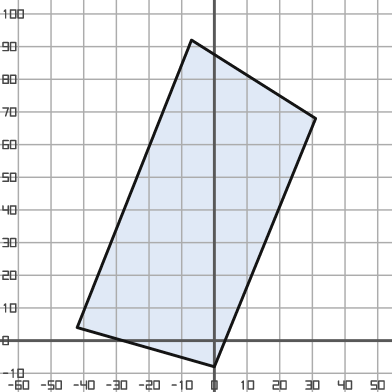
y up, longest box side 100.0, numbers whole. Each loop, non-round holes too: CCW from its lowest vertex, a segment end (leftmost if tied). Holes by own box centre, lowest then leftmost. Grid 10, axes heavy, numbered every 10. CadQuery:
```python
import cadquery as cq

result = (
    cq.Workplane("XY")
    .moveTo(0.0, -8.0)
    .lineTo(31.0, 68.0)
    .lineTo(-7.0, 92.0)
    .lineTo(-42.0, 4.0)
    .close()
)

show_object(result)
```